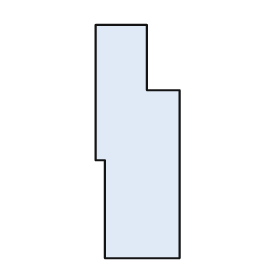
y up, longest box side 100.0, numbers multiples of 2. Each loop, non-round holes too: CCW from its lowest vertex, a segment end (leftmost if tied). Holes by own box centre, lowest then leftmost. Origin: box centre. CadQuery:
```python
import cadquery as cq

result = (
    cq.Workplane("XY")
    .moveTo(-14.0, -50.0)
    .lineTo(18.0, -50.0)
    .lineTo(18.0, 22.0)
    .lineTo(4.0, 22.0)
    .lineTo(4.0, 50.0)
    .lineTo(-18.0, 50.0)
    .lineTo(-18.0, -8.0)
    .lineTo(-14.0, -8.0)
    .close()
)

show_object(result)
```